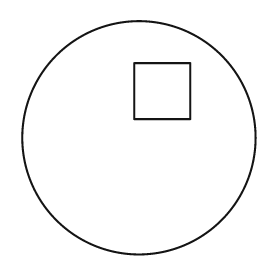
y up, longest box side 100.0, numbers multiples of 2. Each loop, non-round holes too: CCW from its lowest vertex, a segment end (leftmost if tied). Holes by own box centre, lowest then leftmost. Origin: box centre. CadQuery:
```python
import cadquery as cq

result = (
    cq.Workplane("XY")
    .moveTo(0.0, 0.0)
    .circle(50.0)
    .moveTo(-2.0, 8.0)
    .lineTo(22.0, 8.0)
    .lineTo(22.0, 32.0)
    .lineTo(-2.0, 32.0)
    .close()
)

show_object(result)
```